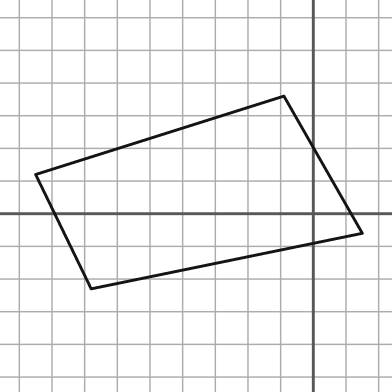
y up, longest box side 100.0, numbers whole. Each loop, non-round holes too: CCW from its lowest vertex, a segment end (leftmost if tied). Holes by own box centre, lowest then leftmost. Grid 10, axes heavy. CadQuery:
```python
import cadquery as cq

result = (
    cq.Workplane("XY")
    .moveTo(-68.0, -23.0)
    .lineTo(15.0, -6.0)
    .lineTo(-9.0, 36.0)
    .lineTo(-85.0, 12.0)
    .close()
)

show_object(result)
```